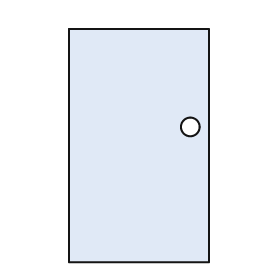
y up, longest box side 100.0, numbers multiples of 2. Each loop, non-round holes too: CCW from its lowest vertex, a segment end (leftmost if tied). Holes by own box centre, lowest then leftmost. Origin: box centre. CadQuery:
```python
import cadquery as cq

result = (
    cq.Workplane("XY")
    .moveTo(-30.0, -50.0)
    .lineTo(30.0, -50.0)
    .lineTo(30.0, 50.0)
    .lineTo(-30.0, 50.0)
    .close()
    .moveTo(22.0, 8.0)
    .circle(4.0)
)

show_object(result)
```